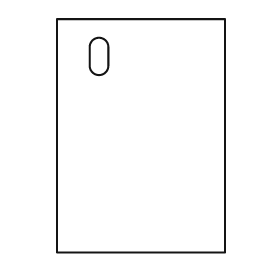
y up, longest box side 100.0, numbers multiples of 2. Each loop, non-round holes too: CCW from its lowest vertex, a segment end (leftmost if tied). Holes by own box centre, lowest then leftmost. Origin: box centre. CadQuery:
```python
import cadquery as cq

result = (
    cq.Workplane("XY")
    .moveTo(-36.0, -50.0)
    .lineTo(36.0, -50.0)
    .lineTo(36.0, 50.0)
    .lineTo(-36.0, 50.0)
    .close()
    .moveTo(-22.0, 30.0)
    .threePointArc((-18.0, 26.0), (-14.0, 30.0))
    .lineTo(-14.0, 38.0)
    .threePointArc((-18.0, 42.0), (-22.0, 38.0))
    .close()
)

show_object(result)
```